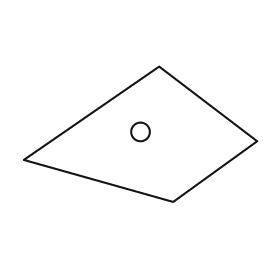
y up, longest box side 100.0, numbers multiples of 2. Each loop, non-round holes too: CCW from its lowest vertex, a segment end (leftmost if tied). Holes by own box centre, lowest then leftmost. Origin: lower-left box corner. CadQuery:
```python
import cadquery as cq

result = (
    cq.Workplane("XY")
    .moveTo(64.0, 0.0)
    .lineTo(100.0, 26.0)
    .lineTo(58.0, 58.0)
    .lineTo(0.0, 18.0)
    .close()
    .moveTo(50.0, 30.0)
    .circle(4.0)
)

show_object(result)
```